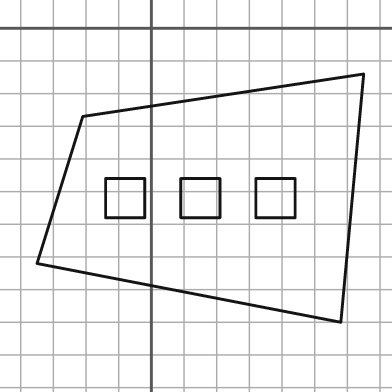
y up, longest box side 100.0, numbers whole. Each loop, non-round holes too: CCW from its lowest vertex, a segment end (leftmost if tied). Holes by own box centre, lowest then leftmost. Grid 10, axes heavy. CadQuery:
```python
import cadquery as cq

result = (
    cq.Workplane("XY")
    .moveTo(58.0, -90.0)
    .lineTo(65.0, -14.0)
    .lineTo(-21.0, -27.0)
    .lineTo(-35.0, -72.0)
    .close()
    .moveTo(-14.0, -58.0)
    .lineTo(-2.0, -58.0)
    .lineTo(-2.0, -46.0)
    .lineTo(-14.0, -46.0)
    .close()
    .moveTo(9.0, -58.0)
    .lineTo(21.0, -58.0)
    .lineTo(21.0, -46.0)
    .lineTo(9.0, -46.0)
    .close()
    .moveTo(32.0, -58.0)
    .lineTo(44.0, -58.0)
    .lineTo(44.0, -46.0)
    .lineTo(32.0, -46.0)
    .close()
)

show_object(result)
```